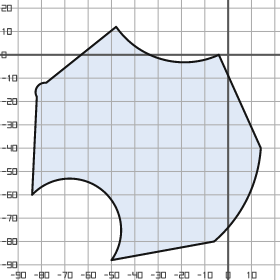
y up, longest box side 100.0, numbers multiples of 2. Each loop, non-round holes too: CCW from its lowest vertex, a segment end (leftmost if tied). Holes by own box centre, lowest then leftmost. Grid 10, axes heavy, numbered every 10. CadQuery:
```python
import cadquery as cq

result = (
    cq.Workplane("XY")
    .moveTo(-50.0, -88.0)
    .lineTo(-6.0, -80.0)
    .threePointArc((8.0, -62.0), (14.0, -40.0))
    .lineTo(-4.0, 0.0)
    .threePointArc((-28.0, -2.0), (-48.0, 12.0))
    .lineTo(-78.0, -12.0)
    .threePointArc((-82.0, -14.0), (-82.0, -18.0))
    .lineTo(-84.0, -60.0)
    .threePointArc((-54.0, -58.0), (-50.0, -88.0))
    .close()
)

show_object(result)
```